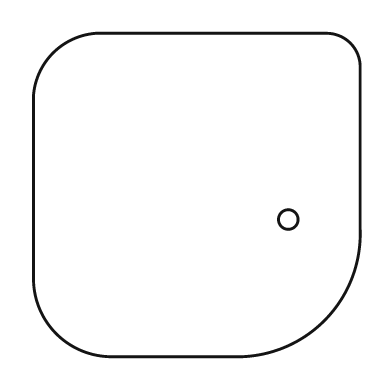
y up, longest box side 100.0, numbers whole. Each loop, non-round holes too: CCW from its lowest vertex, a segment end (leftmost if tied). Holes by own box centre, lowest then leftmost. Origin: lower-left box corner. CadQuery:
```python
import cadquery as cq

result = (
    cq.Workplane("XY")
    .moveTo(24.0, 0.0)
    .lineTo(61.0, 0.0)
    .threePointArc((89.0, 11.0), (100.0, 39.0))
    .lineTo(100.0, 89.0)
    .threePointArc((97.0, 96.0), (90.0, 99.0))
    .lineTo(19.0, 99.0)
    .threePointArc((6.0, 93.0), (0.0, 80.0))
    .lineTo(0.0, 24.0)
    .threePointArc((7.0, 7.0), (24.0, 0.0))
    .close()
    .moveTo(78.0, 42.0)
    .circle(3.0)
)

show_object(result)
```